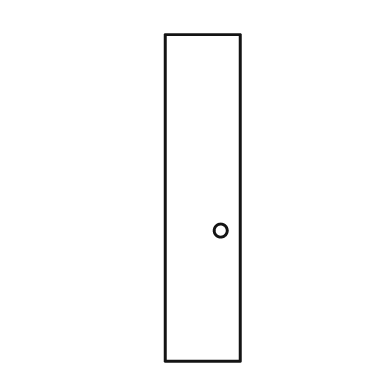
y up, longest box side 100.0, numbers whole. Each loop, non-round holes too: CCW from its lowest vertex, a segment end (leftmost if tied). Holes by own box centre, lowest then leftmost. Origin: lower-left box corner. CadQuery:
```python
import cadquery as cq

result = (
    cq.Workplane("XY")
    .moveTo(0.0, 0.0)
    .lineTo(23.0, 0.0)
    .lineTo(23.0, 100.0)
    .lineTo(0.0, 100.0)
    .close()
    .moveTo(17.0, 40.0)
    .circle(2.0)
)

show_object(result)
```